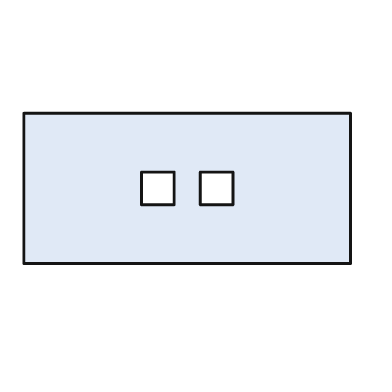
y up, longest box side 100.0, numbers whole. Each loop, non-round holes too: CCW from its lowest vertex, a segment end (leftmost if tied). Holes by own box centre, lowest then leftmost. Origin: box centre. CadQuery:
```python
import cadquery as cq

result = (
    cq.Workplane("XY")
    .moveTo(-50.0, -23.0)
    .lineTo(50.0, -23.0)
    .lineTo(50.0, 23.0)
    .lineTo(-50.0, 23.0)
    .close()
    .moveTo(-14.0, -5.0)
    .lineTo(-4.0, -5.0)
    .lineTo(-4.0, 5.0)
    .lineTo(-14.0, 5.0)
    .close()
    .moveTo(4.0, -5.0)
    .lineTo(14.0, -5.0)
    .lineTo(14.0, 5.0)
    .lineTo(4.0, 5.0)
    .close()
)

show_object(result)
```